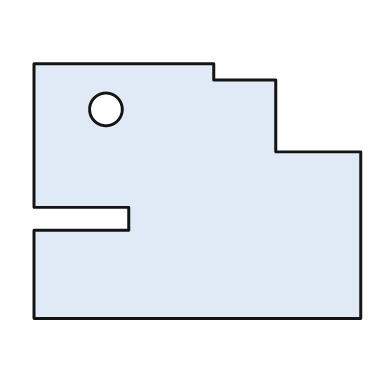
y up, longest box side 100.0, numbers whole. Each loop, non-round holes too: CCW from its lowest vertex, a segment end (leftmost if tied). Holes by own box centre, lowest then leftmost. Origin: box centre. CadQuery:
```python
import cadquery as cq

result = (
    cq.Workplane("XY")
    .moveTo(-50.0, -39.0)
    .lineTo(50.0, -39.0)
    .lineTo(50.0, 12.0)
    .lineTo(24.0, 12.0)
    .lineTo(24.0, 34.0)
    .lineTo(5.0, 34.0)
    .lineTo(5.0, 39.0)
    .lineTo(-50.0, 39.0)
    .lineTo(-50.0, -5.0)
    .lineTo(-21.0, -5.0)
    .lineTo(-21.0, -12.0)
    .lineTo(-50.0, -12.0)
    .close()
    .moveTo(-28.0, 25.0)
    .circle(5.0)
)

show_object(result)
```